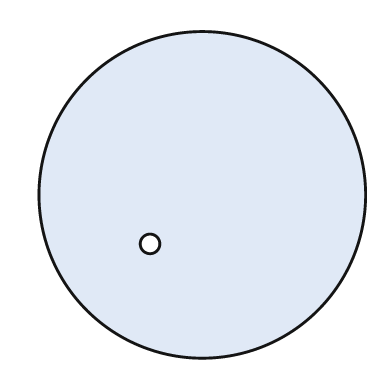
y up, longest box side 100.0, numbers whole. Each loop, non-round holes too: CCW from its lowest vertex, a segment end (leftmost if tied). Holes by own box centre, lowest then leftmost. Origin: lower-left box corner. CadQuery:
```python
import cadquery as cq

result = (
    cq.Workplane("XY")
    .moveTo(50.0, 50.0)
    .circle(50.0)
    .moveTo(34.0, 35.0)
    .circle(3.0)
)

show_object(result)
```